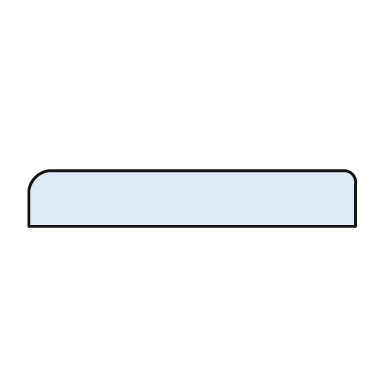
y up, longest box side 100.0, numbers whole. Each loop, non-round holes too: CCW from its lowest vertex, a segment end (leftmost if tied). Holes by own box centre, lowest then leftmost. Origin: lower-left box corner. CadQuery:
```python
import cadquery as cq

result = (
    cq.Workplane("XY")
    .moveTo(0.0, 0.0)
    .lineTo(100.0, 0.0)
    .lineTo(100.0, 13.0)
    .threePointArc((99.0, 16.0), (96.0, 17.0))
    .lineTo(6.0, 17.0)
    .threePointArc((2.0, 15.0), (0.0, 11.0))
    .close()
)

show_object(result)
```